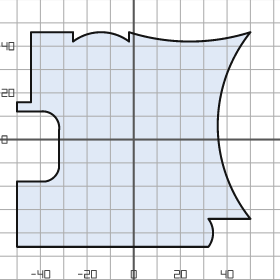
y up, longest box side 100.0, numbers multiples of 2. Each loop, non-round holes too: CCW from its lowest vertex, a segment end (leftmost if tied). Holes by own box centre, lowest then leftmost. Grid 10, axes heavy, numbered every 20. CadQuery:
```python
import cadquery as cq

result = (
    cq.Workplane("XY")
    .moveTo(-50.0, -46.0)
    .lineTo(32.0, -46.0)
    .threePointArc((34.0, -40.0), (32.0, -34.0))
    .lineTo(50.0, -34.0)
    .threePointArc((36.0, 6.0), (50.0, 46.0))
    .threePointArc((24.0, 42.0), (-2.0, 46.0))
    .lineTo(-2.0, 42.0)
    .threePointArc((-14.0, 46.0), (-26.0, 42.0))
    .lineTo(-26.0, 46.0)
    .lineTo(-44.0, 46.0)
    .lineTo(-44.0, 16.0)
    .lineTo(-50.0, 16.0)
    .lineTo(-50.0, 12.0)
    .lineTo(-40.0, 12.0)
    .threePointArc((-34.0, 10.0), (-32.0, 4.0))
    .lineTo(-32.0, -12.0)
    .threePointArc((-34.0, -16.0), (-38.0, -18.0))
    .lineTo(-50.0, -18.0)
    .close()
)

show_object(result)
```